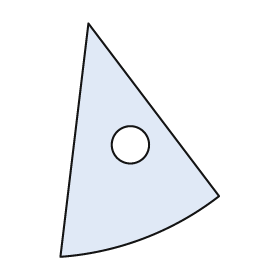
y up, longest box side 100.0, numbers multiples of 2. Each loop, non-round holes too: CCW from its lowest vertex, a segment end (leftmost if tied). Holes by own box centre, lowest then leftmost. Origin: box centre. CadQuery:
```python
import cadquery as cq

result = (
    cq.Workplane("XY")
    .moveTo(-34.0, -50.0)
    .threePointArc((2.0, -42.0), (34.0, -24.0))
    .lineTo(-22.0, 50.0)
    .close()
    .moveTo(-4.0, -2.0)
    .circle(8.0)
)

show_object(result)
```